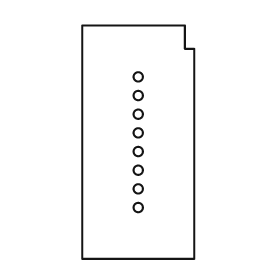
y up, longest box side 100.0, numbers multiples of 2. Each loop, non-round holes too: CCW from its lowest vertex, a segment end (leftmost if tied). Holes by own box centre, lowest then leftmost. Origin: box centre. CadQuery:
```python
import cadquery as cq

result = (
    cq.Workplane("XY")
    .moveTo(-24.0, -50.0)
    .lineTo(24.0, -50.0)
    .lineTo(24.0, 40.0)
    .lineTo(20.0, 40.0)
    .lineTo(20.0, 50.0)
    .lineTo(-24.0, 50.0)
    .close()
    .moveTo(0.0, -28.0)
    .circle(2.0)
    .moveTo(0.0, -20.0)
    .circle(2.0)
    .moveTo(0.0, -12.0)
    .circle(2.0)
    .moveTo(0.0, -4.0)
    .circle(2.0)
    .moveTo(0.0, 4.0)
    .circle(2.0)
    .moveTo(0.0, 12.0)
    .circle(2.0)
    .moveTo(0.0, 20.0)
    .circle(2.0)
    .moveTo(0.0, 28.0)
    .circle(2.0)
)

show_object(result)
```